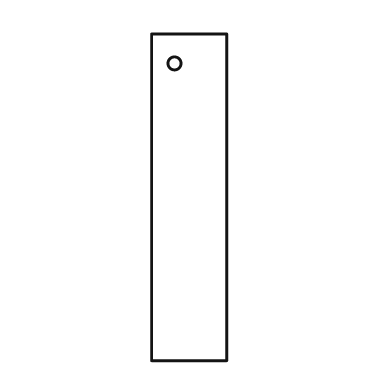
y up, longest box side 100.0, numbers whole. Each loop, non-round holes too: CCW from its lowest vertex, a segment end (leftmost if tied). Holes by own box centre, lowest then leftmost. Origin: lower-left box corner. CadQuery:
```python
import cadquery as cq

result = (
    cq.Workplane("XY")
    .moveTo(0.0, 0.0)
    .lineTo(23.0, 0.0)
    .lineTo(23.0, 100.0)
    .lineTo(0.0, 100.0)
    .close()
    .moveTo(7.0, 91.0)
    .circle(2.0)
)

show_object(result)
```